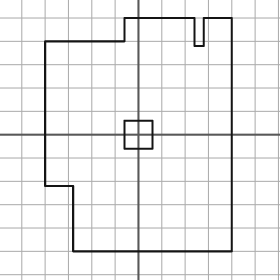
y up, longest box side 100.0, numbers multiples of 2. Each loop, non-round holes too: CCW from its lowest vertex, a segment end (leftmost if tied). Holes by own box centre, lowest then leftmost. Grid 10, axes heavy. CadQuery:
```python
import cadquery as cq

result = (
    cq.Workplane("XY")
    .moveTo(-28.0, -50.0)
    .lineTo(40.0, -50.0)
    .lineTo(40.0, 50.0)
    .lineTo(28.0, 50.0)
    .lineTo(28.0, 38.0)
    .lineTo(24.0, 38.0)
    .lineTo(24.0, 50.0)
    .lineTo(-6.0, 50.0)
    .lineTo(-6.0, 40.0)
    .lineTo(-40.0, 40.0)
    .lineTo(-40.0, -22.0)
    .lineTo(-28.0, -22.0)
    .close()
    .moveTo(-6.0, -6.0)
    .lineTo(6.0, -6.0)
    .lineTo(6.0, 6.0)
    .lineTo(-6.0, 6.0)
    .close()
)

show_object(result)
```